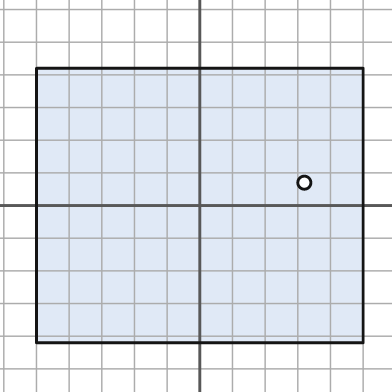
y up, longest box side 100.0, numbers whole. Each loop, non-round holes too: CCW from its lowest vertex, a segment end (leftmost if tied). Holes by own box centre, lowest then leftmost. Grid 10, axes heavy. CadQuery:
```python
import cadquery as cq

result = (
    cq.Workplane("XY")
    .moveTo(-50.0, -42.0)
    .lineTo(50.0, -42.0)
    .lineTo(50.0, 42.0)
    .lineTo(-50.0, 42.0)
    .close()
    .moveTo(32.0, 7.0)
    .circle(2.0)
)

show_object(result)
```